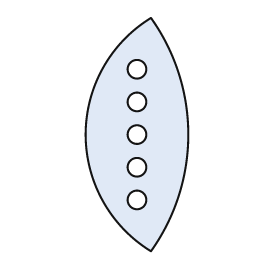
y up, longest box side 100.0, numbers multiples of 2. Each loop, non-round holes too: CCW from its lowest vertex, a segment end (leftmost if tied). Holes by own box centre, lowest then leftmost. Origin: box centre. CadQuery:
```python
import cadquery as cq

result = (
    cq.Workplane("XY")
    .moveTo(6.0, -50.0)
    .threePointArc((22.0, 0.0), (6.0, 50.0))
    .threePointArc((-22.0, 0.0), (6.0, -50.0))
    .close()
    .moveTo(0.0, -28.0)
    .circle(4.0)
    .moveTo(0.0, -14.0)
    .circle(4.0)
    .moveTo(0.0, 0.0)
    .circle(4.0)
    .moveTo(0.0, 14.0)
    .circle(4.0)
    .moveTo(0.0, 28.0)
    .circle(4.0)
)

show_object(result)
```